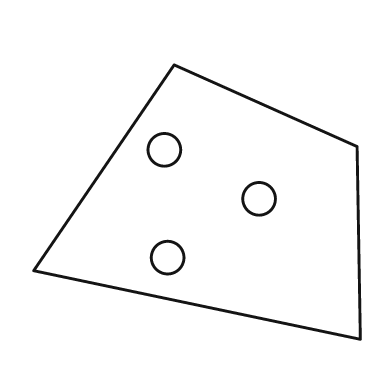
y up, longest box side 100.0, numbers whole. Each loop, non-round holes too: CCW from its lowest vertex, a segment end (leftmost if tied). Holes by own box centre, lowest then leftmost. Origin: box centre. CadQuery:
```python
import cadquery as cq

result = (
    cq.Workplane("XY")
    .moveTo(50.0, -42.0)
    .lineTo(49.0, 17.0)
    .lineTo(-7.0, 42.0)
    .lineTo(-50.0, -21.0)
    .close()
    .moveTo(-9.0, -17.0)
    .circle(5.0)
    .moveTo(19.0, 1.0)
    .circle(5.0)
    .moveTo(-10.0, 16.0)
    .circle(5.0)
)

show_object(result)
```